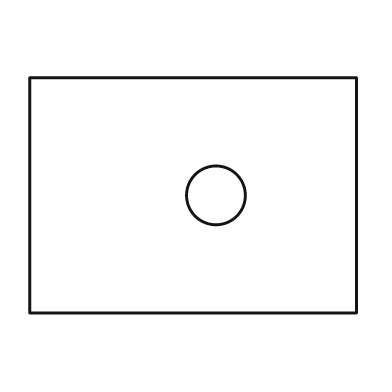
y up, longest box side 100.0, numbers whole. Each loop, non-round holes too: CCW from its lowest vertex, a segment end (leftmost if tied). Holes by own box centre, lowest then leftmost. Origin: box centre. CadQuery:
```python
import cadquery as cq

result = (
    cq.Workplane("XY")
    .moveTo(-50.0, -36.0)
    .lineTo(50.0, -36.0)
    .lineTo(50.0, 36.0)
    .lineTo(-50.0, 36.0)
    .close()
    .moveTo(7.0, 0.0)
    .circle(9.0)
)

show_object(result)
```